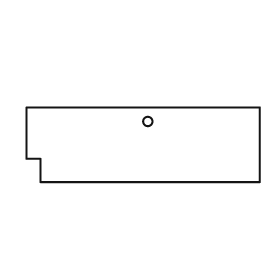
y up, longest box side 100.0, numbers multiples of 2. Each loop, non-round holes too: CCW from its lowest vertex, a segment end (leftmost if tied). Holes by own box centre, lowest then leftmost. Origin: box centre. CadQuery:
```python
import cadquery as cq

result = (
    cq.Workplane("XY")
    .moveTo(-44.0, -16.0)
    .lineTo(50.0, -16.0)
    .lineTo(50.0, 16.0)
    .lineTo(-50.0, 16.0)
    .lineTo(-50.0, -6.0)
    .lineTo(-44.0, -6.0)
    .close()
    .moveTo(2.0, 10.0)
    .circle(2.0)
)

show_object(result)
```